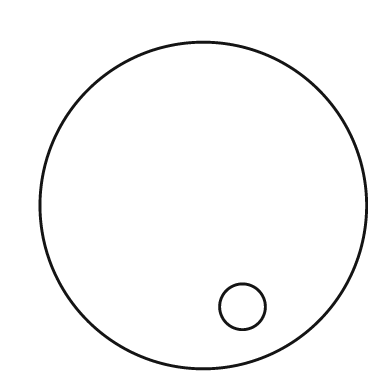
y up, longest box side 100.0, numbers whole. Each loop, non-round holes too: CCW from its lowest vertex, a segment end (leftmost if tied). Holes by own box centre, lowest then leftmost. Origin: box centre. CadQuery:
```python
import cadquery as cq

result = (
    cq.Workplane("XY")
    .moveTo(0.0, 0.0)
    .circle(50.0)
    .moveTo(12.0, -31.0)
    .circle(7.0)
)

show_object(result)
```